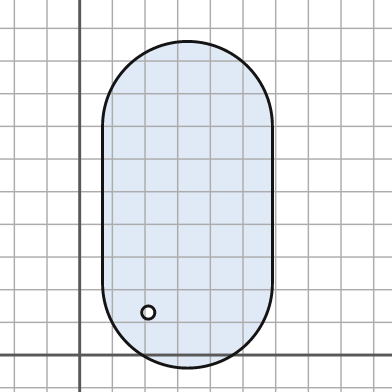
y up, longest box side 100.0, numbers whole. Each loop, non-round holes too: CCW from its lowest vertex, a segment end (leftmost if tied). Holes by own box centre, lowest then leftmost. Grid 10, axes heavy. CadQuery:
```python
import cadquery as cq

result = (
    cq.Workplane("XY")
    .moveTo(7.0, 22.0)
    .threePointArc((33.0, -4.0), (59.0, 22.0))
    .lineTo(59.0, 70.0)
    .threePointArc((33.0, 96.0), (7.0, 70.0))
    .close()
    .moveTo(21.0, 13.0)
    .circle(2.0)
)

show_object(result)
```